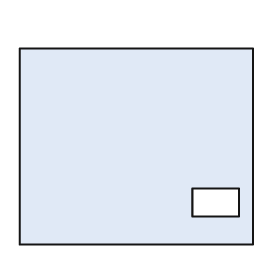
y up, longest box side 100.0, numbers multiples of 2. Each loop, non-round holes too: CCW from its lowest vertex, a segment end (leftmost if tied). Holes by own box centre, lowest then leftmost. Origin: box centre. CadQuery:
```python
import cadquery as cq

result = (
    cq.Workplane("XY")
    .moveTo(-50.0, -42.0)
    .lineTo(50.0, -42.0)
    .lineTo(50.0, 42.0)
    .lineTo(-50.0, 42.0)
    .close()
    .moveTo(24.0, -30.0)
    .lineTo(44.0, -30.0)
    .lineTo(44.0, -18.0)
    .lineTo(24.0, -18.0)
    .close()
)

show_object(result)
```